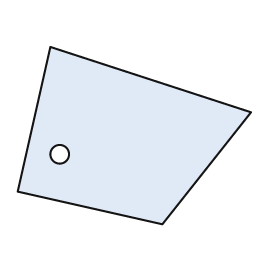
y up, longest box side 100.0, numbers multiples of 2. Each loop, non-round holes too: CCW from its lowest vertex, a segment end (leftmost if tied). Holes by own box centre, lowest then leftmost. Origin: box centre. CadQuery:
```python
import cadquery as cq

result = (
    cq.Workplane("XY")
    .moveTo(12.0, -38.0)
    .lineTo(50.0, 10.0)
    .lineTo(-36.0, 38.0)
    .lineTo(-50.0, -24.0)
    .close()
    .moveTo(-32.0, -8.0)
    .circle(4.0)
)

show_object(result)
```